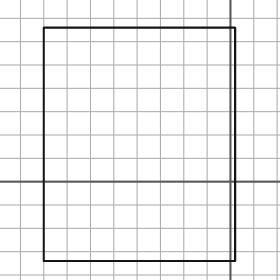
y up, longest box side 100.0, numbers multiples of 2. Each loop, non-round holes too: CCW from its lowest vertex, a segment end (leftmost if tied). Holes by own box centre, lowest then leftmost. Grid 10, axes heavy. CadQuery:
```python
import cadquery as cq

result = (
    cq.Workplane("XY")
    .moveTo(-80.0, -34.0)
    .lineTo(2.0, -34.0)
    .lineTo(2.0, 66.0)
    .lineTo(-80.0, 66.0)
    .close()
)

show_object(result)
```